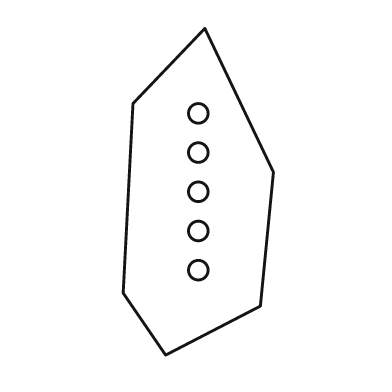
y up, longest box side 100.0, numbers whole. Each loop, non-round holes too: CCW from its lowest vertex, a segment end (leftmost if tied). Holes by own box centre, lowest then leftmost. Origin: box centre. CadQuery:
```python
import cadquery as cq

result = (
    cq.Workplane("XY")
    .moveTo(-10.0, -50.0)
    .lineTo(19.0, -35.0)
    .lineTo(23.0, 6.0)
    .lineTo(2.0, 50.0)
    .lineTo(-20.0, 27.0)
    .lineTo(-23.0, -31.0)
    .close()
    .moveTo(0.0, -24.0)
    .circle(3.0)
    .moveTo(0.0, -12.0)
    .circle(3.0)
    .moveTo(0.0, 0.0)
    .circle(3.0)
    .moveTo(0.0, 12.0)
    .circle(3.0)
    .moveTo(0.0, 24.0)
    .circle(3.0)
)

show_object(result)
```